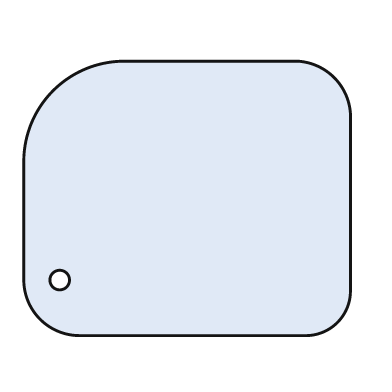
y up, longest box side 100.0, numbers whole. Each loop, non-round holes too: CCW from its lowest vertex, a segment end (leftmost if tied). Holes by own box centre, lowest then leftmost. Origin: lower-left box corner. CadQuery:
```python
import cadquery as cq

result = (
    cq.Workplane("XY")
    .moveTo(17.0, 0.0)
    .lineTo(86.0, 0.0)
    .threePointArc((96.0, 4.0), (100.0, 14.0))
    .lineTo(100.0, 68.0)
    .threePointArc((95.0, 79.0), (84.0, 84.0))
    .lineTo(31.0, 84.0)
    .threePointArc((9.0, 75.0), (0.0, 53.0))
    .lineTo(0.0, 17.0)
    .threePointArc((5.0, 5.0), (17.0, 0.0))
    .close()
    .moveTo(11.0, 17.0)
    .circle(3.0)
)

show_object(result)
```